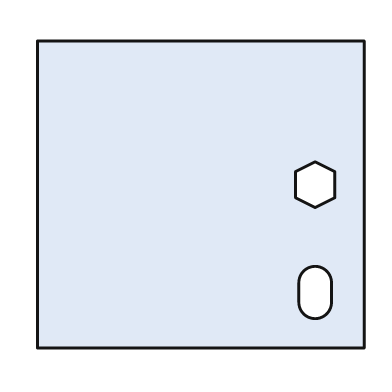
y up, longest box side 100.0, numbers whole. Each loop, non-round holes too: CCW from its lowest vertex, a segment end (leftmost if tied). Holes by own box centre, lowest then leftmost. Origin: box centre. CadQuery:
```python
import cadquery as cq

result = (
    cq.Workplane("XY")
    .moveTo(-50.0, -47.0)
    .lineTo(50.0, -47.0)
    .lineTo(50.0, 47.0)
    .lineTo(-50.0, 47.0)
    .close()
    .moveTo(30.0, -33.0)
    .threePointArc((35.0, -38.0), (40.0, -33.0))
    .lineTo(40.0, -27.0)
    .threePointArc((35.0, -22.0), (30.0, -27.0))
    .close()
    .moveTo(35.0, -4.0)
    .lineTo(41.0, -1.0)
    .lineTo(41.0, 7.0)
    .lineTo(35.0, 10.0)
    .lineTo(29.0, 7.0)
    .lineTo(29.0, -1.0)
    .close()
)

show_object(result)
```